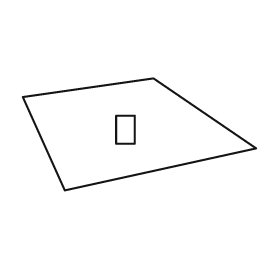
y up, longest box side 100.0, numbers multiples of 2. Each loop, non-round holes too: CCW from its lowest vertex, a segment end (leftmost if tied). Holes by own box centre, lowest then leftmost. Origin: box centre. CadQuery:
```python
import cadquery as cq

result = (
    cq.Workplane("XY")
    .moveTo(-32.0, -24.0)
    .lineTo(50.0, -6.0)
    .lineTo(6.0, 24.0)
    .lineTo(-50.0, 16.0)
    .close()
    .moveTo(-10.0, -4.0)
    .lineTo(-2.0, -4.0)
    .lineTo(-2.0, 8.0)
    .lineTo(-10.0, 8.0)
    .close()
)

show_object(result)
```